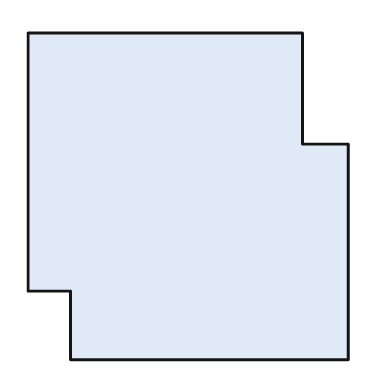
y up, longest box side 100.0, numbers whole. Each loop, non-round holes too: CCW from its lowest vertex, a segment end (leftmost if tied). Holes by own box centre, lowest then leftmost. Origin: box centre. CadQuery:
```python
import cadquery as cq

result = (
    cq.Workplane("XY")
    .moveTo(-36.0, -50.0)
    .lineTo(49.0, -50.0)
    .lineTo(49.0, 16.0)
    .lineTo(35.0, 16.0)
    .lineTo(35.0, 50.0)
    .lineTo(-49.0, 50.0)
    .lineTo(-49.0, -29.0)
    .lineTo(-36.0, -29.0)
    .close()
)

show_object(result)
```